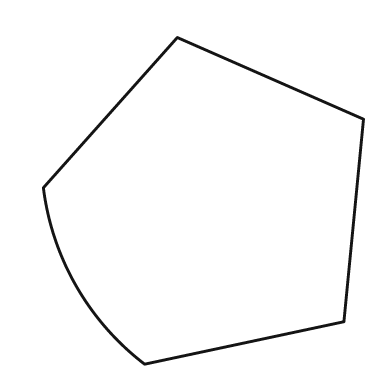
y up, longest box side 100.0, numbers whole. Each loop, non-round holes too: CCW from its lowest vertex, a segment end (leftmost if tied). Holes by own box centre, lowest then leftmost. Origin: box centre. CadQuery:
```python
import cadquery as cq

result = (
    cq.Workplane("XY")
    .moveTo(-18.0, -50.0)
    .lineTo(43.0, -37.0)
    .lineTo(49.0, 25.0)
    .lineTo(-8.0, 50.0)
    .lineTo(-49.0, 4.0)
    .threePointArc((-39.0, -26.0), (-18.0, -50.0))
    .close()
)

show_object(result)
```